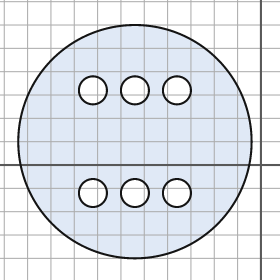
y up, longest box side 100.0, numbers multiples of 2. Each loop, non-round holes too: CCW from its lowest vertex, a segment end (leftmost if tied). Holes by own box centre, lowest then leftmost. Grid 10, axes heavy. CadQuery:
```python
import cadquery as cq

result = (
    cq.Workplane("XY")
    .moveTo(-54.0, 10.0)
    .circle(50.0)
    .moveTo(-72.0, -12.0)
    .circle(6.0)
    .moveTo(-54.0, -12.0)
    .circle(6.0)
    .moveTo(-36.0, -12.0)
    .circle(6.0)
    .moveTo(-72.0, 32.0)
    .circle(6.0)
    .moveTo(-54.0, 32.0)
    .circle(6.0)
    .moveTo(-36.0, 32.0)
    .circle(6.0)
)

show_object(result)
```